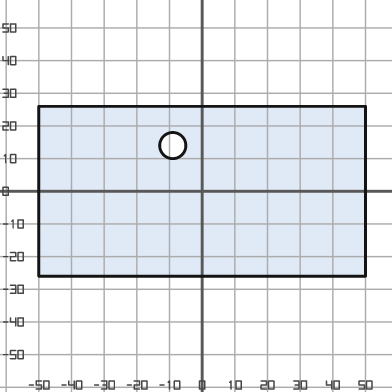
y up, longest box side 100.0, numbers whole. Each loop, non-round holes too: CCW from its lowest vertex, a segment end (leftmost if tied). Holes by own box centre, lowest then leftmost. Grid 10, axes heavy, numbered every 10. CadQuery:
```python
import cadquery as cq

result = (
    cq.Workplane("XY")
    .moveTo(-50.0, -26.0)
    .lineTo(50.0, -26.0)
    .lineTo(50.0, 26.0)
    .lineTo(-50.0, 26.0)
    .close()
    .moveTo(-9.0, 14.0)
    .circle(4.0)
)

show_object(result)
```